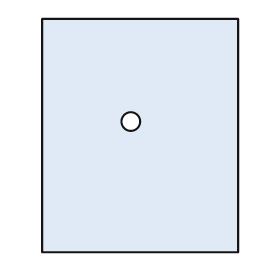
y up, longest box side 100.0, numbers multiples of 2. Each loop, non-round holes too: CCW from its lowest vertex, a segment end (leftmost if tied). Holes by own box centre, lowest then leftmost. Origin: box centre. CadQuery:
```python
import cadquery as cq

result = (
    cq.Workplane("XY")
    .moveTo(-42.0, -50.0)
    .lineTo(42.0, -50.0)
    .lineTo(42.0, 50.0)
    .lineTo(-42.0, 50.0)
    .close()
    .moveTo(-4.0, 6.0)
    .circle(4.0)
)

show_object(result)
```